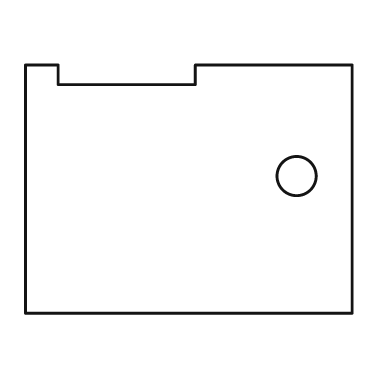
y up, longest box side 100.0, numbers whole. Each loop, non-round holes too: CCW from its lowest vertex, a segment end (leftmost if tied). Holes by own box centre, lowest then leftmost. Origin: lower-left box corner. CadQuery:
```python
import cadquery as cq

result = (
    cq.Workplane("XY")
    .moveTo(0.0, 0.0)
    .lineTo(100.0, 0.0)
    .lineTo(100.0, 76.0)
    .lineTo(52.0, 76.0)
    .lineTo(52.0, 70.0)
    .lineTo(10.0, 70.0)
    .lineTo(10.0, 76.0)
    .lineTo(0.0, 76.0)
    .close()
    .moveTo(83.0, 42.0)
    .circle(6.0)
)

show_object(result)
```